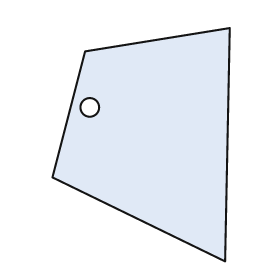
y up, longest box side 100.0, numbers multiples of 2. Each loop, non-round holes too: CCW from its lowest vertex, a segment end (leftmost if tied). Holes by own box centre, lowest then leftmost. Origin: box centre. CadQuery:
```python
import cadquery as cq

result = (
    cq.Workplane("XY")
    .moveTo(36.0, -50.0)
    .lineTo(38.0, 50.0)
    .lineTo(-24.0, 40.0)
    .lineTo(-38.0, -14.0)
    .close()
    .moveTo(-22.0, 16.0)
    .circle(4.0)
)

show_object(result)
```